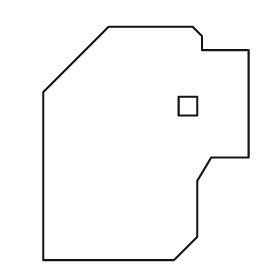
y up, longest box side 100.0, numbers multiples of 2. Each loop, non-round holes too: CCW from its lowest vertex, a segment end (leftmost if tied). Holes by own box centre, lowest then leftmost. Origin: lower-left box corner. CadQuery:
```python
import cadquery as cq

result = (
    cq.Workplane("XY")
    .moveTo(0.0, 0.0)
    .lineTo(56.0, 0.0)
    .lineTo(66.0, 10.0)
    .lineTo(66.0, 34.0)
    .lineTo(72.0, 44.0)
    .lineTo(88.0, 44.0)
    .lineTo(88.0, 90.0)
    .lineTo(68.0, 90.0)
    .lineTo(68.0, 96.0)
    .lineTo(64.0, 100.0)
    .lineTo(28.0, 100.0)
    .lineTo(0.0, 72.0)
    .close()
    .moveTo(58.0, 62.0)
    .lineTo(66.0, 62.0)
    .lineTo(66.0, 70.0)
    .lineTo(58.0, 70.0)
    .close()
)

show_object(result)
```